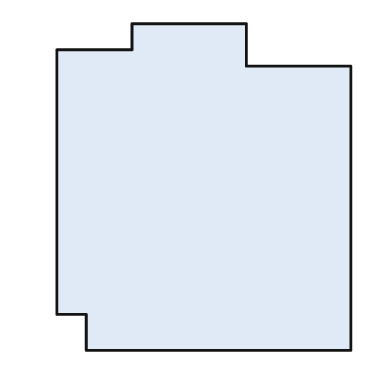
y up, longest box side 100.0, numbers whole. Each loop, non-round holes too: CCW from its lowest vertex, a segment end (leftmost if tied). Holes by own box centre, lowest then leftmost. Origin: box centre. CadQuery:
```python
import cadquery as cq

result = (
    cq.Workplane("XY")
    .moveTo(-36.0, -50.0)
    .lineTo(45.0, -50.0)
    .lineTo(45.0, 37.0)
    .lineTo(13.0, 37.0)
    .lineTo(13.0, 50.0)
    .lineTo(-22.0, 50.0)
    .lineTo(-22.0, 42.0)
    .lineTo(-45.0, 42.0)
    .lineTo(-45.0, -39.0)
    .lineTo(-36.0, -39.0)
    .close()
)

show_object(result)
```